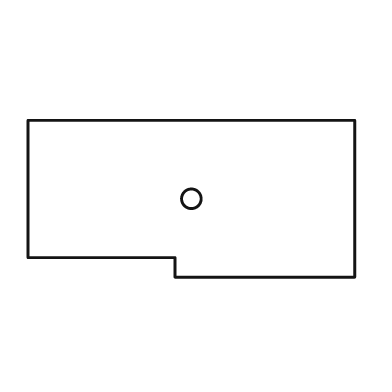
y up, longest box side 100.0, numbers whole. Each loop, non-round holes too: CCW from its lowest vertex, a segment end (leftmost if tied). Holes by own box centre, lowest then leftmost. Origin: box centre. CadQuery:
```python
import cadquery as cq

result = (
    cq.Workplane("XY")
    .moveTo(-5.0, -24.0)
    .lineTo(50.0, -24.0)
    .lineTo(50.0, 24.0)
    .lineTo(-50.0, 24.0)
    .lineTo(-50.0, -18.0)
    .lineTo(-5.0, -18.0)
    .close()
    .moveTo(0.0, 0.0)
    .circle(3.0)
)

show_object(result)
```